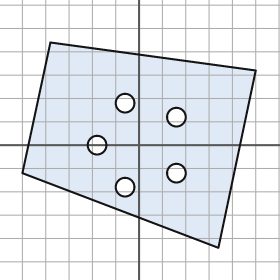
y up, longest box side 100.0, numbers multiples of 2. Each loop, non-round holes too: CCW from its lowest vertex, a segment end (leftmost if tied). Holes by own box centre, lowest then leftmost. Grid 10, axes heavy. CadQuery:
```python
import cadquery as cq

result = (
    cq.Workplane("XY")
    .moveTo(34.0, -44.0)
    .lineTo(50.0, 32.0)
    .lineTo(-38.0, 44.0)
    .lineTo(-50.0, -12.0)
    .close()
    .moveTo(-6.0, -18.0)
    .circle(4.0)
    .moveTo(16.0, -12.0)
    .circle(4.0)
    .moveTo(-18.0, 0.0)
    .circle(4.0)
    .moveTo(16.0, 12.0)
    .circle(4.0)
    .moveTo(-6.0, 18.0)
    .circle(4.0)
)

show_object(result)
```